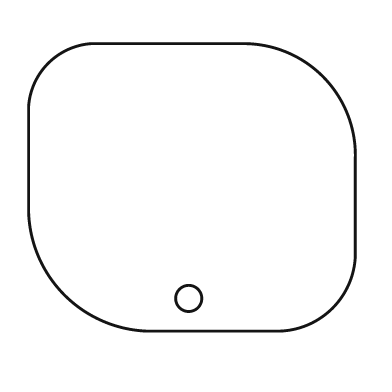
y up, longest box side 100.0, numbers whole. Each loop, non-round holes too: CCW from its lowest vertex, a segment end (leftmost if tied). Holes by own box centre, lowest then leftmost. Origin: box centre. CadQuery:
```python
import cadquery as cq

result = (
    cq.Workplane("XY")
    .moveTo(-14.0, -44.0)
    .lineTo(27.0, -44.0)
    .threePointArc((43.0, -37.0), (50.0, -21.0))
    .lineTo(50.0, 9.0)
    .threePointArc((40.0, 34.0), (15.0, 44.0))
    .lineTo(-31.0, 44.0)
    .threePointArc((-44.0, 38.0), (-50.0, 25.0))
    .lineTo(-50.0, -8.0)
    .threePointArc((-39.0, -33.0), (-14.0, -44.0))
    .close()
    .moveTo(-1.0, -34.0)
    .circle(4.0)
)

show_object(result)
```